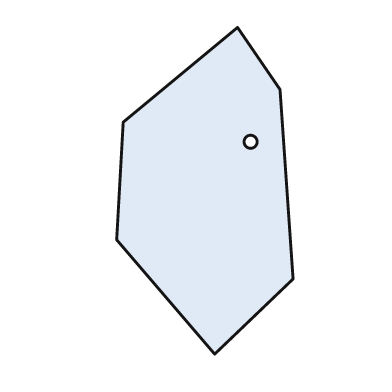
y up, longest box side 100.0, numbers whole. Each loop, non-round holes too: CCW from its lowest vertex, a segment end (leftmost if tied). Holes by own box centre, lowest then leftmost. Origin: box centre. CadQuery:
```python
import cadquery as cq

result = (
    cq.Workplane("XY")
    .moveTo(3.0, -50.0)
    .lineTo(27.0, -27.0)
    .lineTo(23.0, 31.0)
    .lineTo(10.0, 50.0)
    .lineTo(-25.0, 21.0)
    .lineTo(-27.0, -15.0)
    .close()
    .moveTo(14.0, 15.0)
    .circle(2.0)
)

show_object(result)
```